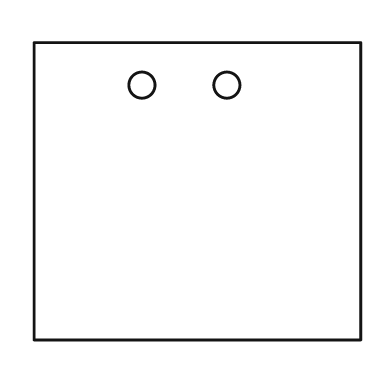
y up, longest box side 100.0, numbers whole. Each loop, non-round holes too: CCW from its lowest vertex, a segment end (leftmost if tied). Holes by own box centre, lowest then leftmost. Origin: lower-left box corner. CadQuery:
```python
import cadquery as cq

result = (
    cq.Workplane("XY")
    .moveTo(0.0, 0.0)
    .lineTo(100.0, 0.0)
    .lineTo(100.0, 91.0)
    .lineTo(0.0, 91.0)
    .close()
    .moveTo(33.0, 78.0)
    .circle(4.0)
    .moveTo(59.0, 78.0)
    .circle(4.0)
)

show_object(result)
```